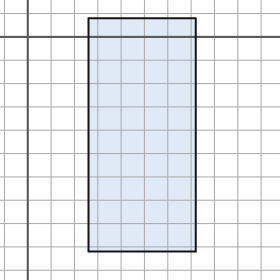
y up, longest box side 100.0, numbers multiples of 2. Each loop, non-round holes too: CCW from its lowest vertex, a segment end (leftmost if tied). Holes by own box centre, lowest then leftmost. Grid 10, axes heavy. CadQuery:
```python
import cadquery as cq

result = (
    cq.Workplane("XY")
    .moveTo(26.0, -92.0)
    .lineTo(72.0, -92.0)
    .lineTo(72.0, 8.0)
    .lineTo(26.0, 8.0)
    .close()
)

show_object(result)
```